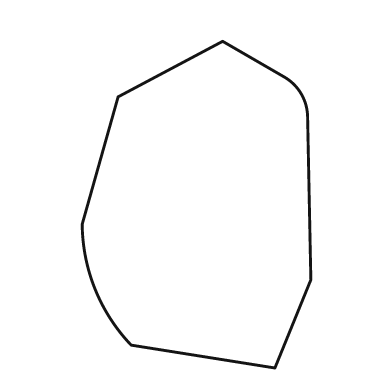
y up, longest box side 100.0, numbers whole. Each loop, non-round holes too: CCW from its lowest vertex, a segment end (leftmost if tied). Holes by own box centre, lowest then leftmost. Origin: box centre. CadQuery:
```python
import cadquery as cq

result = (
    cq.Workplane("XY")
    .moveTo(24.0, -50.0)
    .lineTo(35.0, -23.0)
    .lineTo(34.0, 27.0)
    .threePointArc((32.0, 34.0), (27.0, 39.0))
    .lineTo(8.0, 50.0)
    .lineTo(-24.0, 33.0)
    .lineTo(-35.0, -6.0)
    .threePointArc((-31.0, -26.0), (-20.0, -43.0))
    .close()
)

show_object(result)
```